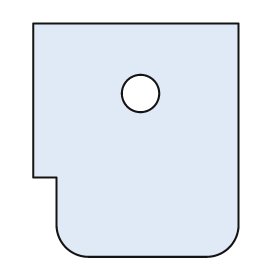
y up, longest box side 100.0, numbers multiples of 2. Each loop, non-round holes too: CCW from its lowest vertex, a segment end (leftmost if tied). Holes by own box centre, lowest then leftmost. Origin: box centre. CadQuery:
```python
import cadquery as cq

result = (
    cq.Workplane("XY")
    .moveTo(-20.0, -50.0)
    .lineTo(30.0, -50.0)
    .threePointArc((40.0, -46.0), (44.0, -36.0))
    .lineTo(44.0, 50.0)
    .lineTo(-44.0, 50.0)
    .lineTo(-44.0, -16.0)
    .lineTo(-34.0, -16.0)
    .lineTo(-34.0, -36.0)
    .threePointArc((-30.0, -46.0), (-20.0, -50.0))
    .close()
    .moveTo(2.0, 20.0)
    .circle(8.0)
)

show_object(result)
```